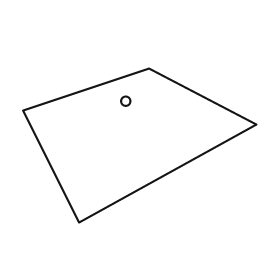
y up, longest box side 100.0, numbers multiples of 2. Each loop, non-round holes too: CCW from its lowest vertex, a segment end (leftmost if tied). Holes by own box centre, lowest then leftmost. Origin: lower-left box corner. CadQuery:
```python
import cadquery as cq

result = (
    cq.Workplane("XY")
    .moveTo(24.0, 0.0)
    .lineTo(100.0, 42.0)
    .lineTo(54.0, 66.0)
    .lineTo(0.0, 48.0)
    .close()
    .moveTo(44.0, 52.0)
    .circle(2.0)
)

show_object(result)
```